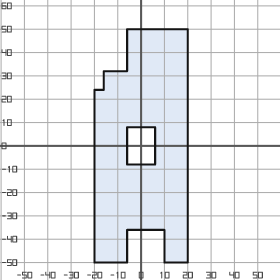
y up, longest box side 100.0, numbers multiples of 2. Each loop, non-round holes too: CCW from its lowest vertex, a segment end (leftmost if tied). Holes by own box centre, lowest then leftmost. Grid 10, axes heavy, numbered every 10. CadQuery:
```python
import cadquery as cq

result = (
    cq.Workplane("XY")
    .moveTo(-20.0, -50.0)
    .lineTo(-6.0, -50.0)
    .lineTo(-6.0, -36.0)
    .lineTo(10.0, -36.0)
    .lineTo(10.0, -50.0)
    .lineTo(20.0, -50.0)
    .lineTo(20.0, 50.0)
    .lineTo(-6.0, 50.0)
    .lineTo(-6.0, 32.0)
    .lineTo(-16.0, 32.0)
    .lineTo(-16.0, 24.0)
    .lineTo(-20.0, 24.0)
    .close()
    .moveTo(-6.0, -8.0)
    .lineTo(6.0, -8.0)
    .lineTo(6.0, 8.0)
    .lineTo(-6.0, 8.0)
    .close()
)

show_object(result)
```